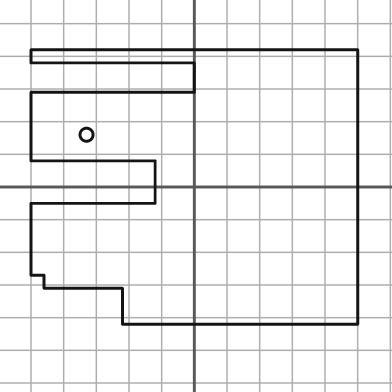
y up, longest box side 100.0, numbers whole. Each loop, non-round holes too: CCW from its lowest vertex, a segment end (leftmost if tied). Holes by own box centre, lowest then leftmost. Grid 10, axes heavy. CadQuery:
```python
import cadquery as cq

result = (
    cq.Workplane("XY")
    .moveTo(-22.0, -42.0)
    .lineTo(50.0, -42.0)
    .lineTo(50.0, 42.0)
    .lineTo(-50.0, 42.0)
    .lineTo(-50.0, 38.0)
    .lineTo(0.0, 38.0)
    .lineTo(0.0, 29.0)
    .lineTo(-50.0, 29.0)
    .lineTo(-50.0, 8.0)
    .lineTo(-12.0, 8.0)
    .lineTo(-12.0, -5.0)
    .lineTo(-50.0, -5.0)
    .lineTo(-50.0, -27.0)
    .lineTo(-46.0, -27.0)
    .lineTo(-46.0, -31.0)
    .lineTo(-22.0, -31.0)
    .close()
    .moveTo(-33.0, 16.0)
    .circle(2.0)
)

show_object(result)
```